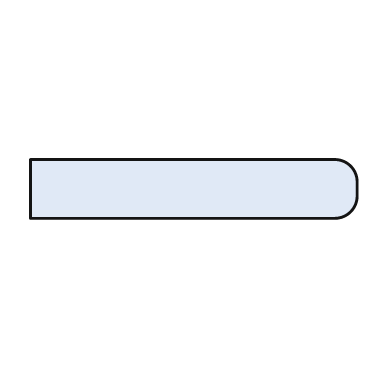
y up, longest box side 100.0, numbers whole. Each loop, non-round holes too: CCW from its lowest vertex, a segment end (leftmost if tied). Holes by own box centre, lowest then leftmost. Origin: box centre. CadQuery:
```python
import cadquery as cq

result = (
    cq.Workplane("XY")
    .moveTo(-50.0, -9.0)
    .lineTo(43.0, -9.0)
    .threePointArc((48.0, -7.0), (50.0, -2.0))
    .lineTo(50.0, 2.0)
    .threePointArc((48.0, 7.0), (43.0, 9.0))
    .lineTo(-50.0, 9.0)
    .close()
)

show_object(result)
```